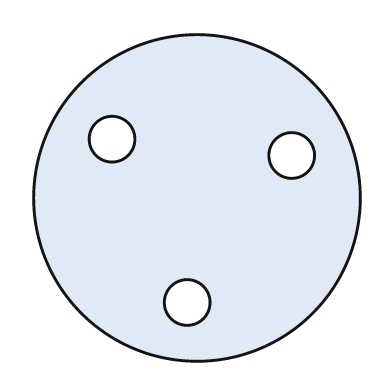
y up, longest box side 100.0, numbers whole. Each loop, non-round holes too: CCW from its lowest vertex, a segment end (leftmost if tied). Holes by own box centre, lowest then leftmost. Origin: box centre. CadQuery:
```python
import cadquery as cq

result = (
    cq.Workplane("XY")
    .moveTo(0.0, 0.0)
    .circle(50.0)
    .moveTo(-3.0, -32.0)
    .circle(7.0)
    .moveTo(29.0, 13.0)
    .circle(7.0)
    .moveTo(-26.0, 18.0)
    .circle(7.0)
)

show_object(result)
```